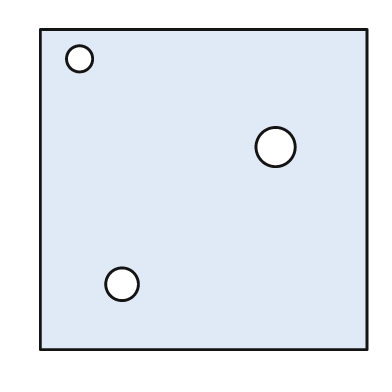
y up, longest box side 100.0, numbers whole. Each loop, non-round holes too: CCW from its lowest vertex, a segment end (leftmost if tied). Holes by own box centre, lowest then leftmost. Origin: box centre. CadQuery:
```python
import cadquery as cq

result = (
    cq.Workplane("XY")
    .moveTo(-50.0, -49.0)
    .lineTo(50.0, -49.0)
    .lineTo(50.0, 49.0)
    .lineTo(-50.0, 49.0)
    .close()
    .moveTo(-25.0, -29.0)
    .circle(5.0)
    .moveTo(22.0, 13.0)
    .circle(6.0)
    .moveTo(-38.0, 40.0)
    .circle(4.0)
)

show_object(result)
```